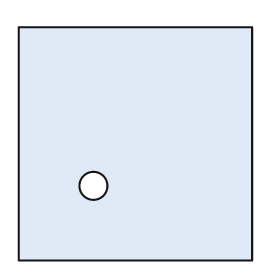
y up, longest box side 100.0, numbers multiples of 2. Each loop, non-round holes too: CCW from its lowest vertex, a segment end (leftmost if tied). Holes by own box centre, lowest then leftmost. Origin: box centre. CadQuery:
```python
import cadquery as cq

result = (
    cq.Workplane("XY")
    .moveTo(-50.0, -50.0)
    .lineTo(50.0, -50.0)
    .lineTo(50.0, 50.0)
    .lineTo(-50.0, 50.0)
    .close()
    .moveTo(-18.0, -18.0)
    .circle(6.0)
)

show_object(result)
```